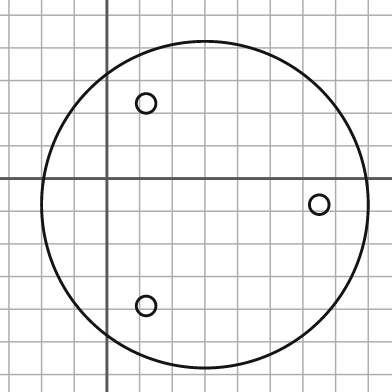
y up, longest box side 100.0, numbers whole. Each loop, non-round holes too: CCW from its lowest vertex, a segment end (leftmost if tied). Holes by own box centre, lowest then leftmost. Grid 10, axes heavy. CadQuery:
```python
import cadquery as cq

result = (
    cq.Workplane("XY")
    .moveTo(30.0, -8.0)
    .circle(50.0)
    .moveTo(12.0, -39.0)
    .circle(3.0)
    .moveTo(65.0, -8.0)
    .circle(3.0)
    .moveTo(12.0, 23.0)
    .circle(3.0)
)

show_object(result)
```